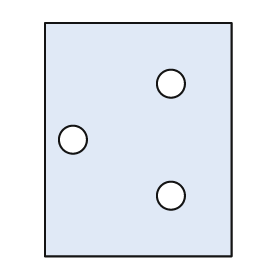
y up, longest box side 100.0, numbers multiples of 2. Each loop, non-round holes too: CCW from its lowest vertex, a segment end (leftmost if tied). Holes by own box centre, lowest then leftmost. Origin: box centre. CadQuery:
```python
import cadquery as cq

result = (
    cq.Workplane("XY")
    .moveTo(-40.0, -50.0)
    .lineTo(40.0, -50.0)
    .lineTo(40.0, 50.0)
    .lineTo(-40.0, 50.0)
    .close()
    .moveTo(14.0, -24.0)
    .circle(6.0)
    .moveTo(-28.0, 0.0)
    .circle(6.0)
    .moveTo(14.0, 24.0)
    .circle(6.0)
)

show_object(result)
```